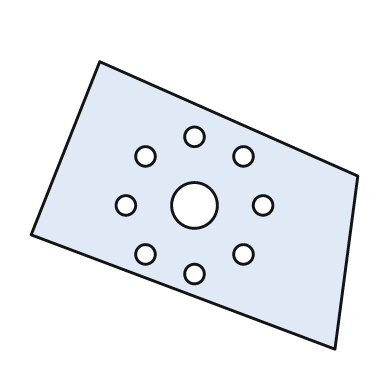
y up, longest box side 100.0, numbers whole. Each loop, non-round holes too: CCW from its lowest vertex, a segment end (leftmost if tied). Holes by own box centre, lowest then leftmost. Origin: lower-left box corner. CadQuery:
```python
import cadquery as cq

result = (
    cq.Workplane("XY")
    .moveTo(93.0, 0.0)
    .lineTo(100.0, 53.0)
    .lineTo(21.0, 88.0)
    .lineTo(0.0, 35.0)
    .close()
    .moveTo(50.0, 23.0)
    .circle(3.0)
    .moveTo(35.0, 29.0)
    .circle(3.0)
    .moveTo(65.0, 29.0)
    .circle(3.0)
    .moveTo(29.0, 44.0)
    .circle(3.0)
    .moveTo(50.0, 44.0)
    .circle(7.0)
    .moveTo(71.0, 44.0)
    .circle(3.0)
    .moveTo(35.0, 59.0)
    .circle(3.0)
    .moveTo(65.0, 59.0)
    .circle(3.0)
    .moveTo(50.0, 65.0)
    .circle(3.0)
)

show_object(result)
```